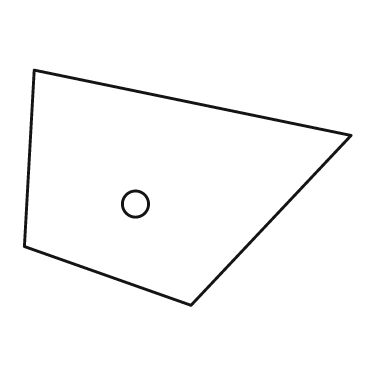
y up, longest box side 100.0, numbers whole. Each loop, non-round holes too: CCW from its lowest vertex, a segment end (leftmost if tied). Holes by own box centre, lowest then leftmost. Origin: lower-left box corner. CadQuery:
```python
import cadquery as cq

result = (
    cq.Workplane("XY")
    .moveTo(51.0, 0.0)
    .lineTo(100.0, 52.0)
    .lineTo(3.0, 72.0)
    .lineTo(0.0, 18.0)
    .close()
    .moveTo(34.0, 31.0)
    .circle(4.0)
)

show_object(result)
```